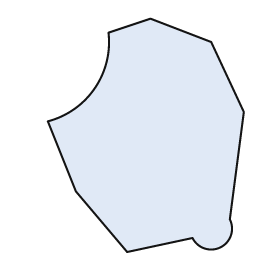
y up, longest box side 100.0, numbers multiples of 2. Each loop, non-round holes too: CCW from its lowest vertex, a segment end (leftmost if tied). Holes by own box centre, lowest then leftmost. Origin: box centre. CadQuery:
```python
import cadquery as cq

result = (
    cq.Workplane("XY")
    .moveTo(-8.0, -50.0)
    .lineTo(20.0, -44.0)
    .threePointArc((32.0, -48.0), (36.0, -36.0))
    .lineTo(42.0, 10.0)
    .lineTo(28.0, 40.0)
    .lineTo(2.0, 50.0)
    .lineTo(-16.0, 44.0)
    .threePointArc((-22.0, 20.0), (-42.0, 6.0))
    .lineTo(-30.0, -24.0)
    .close()
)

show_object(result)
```